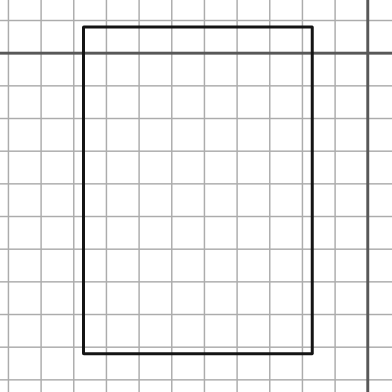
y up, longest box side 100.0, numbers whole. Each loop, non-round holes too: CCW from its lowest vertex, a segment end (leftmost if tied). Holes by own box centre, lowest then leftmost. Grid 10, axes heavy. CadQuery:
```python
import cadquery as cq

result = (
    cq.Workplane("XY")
    .moveTo(-87.0, -92.0)
    .lineTo(-17.0, -92.0)
    .lineTo(-17.0, 8.0)
    .lineTo(-87.0, 8.0)
    .close()
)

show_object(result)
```